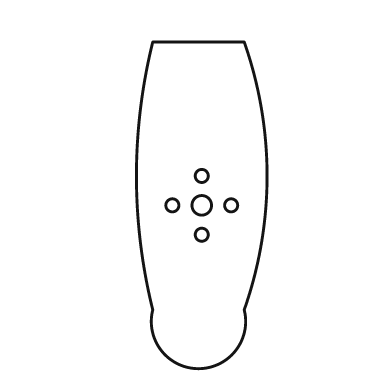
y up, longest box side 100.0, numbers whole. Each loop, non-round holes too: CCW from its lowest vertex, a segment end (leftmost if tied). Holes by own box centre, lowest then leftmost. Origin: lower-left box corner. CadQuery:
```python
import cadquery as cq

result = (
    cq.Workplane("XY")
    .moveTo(5.0, 18.0)
    .threePointArc((19.0, 0.0), (33.0, 18.0))
    .threePointArc((40.0, 59.0), (33.0, 100.0))
    .lineTo(5.0, 100.0)
    .threePointArc((0.0, 59.0), (5.0, 18.0))
    .close()
    .moveTo(20.0, 41.0)
    .circle(2.0)
    .moveTo(11.0, 50.0)
    .circle(2.0)
    .moveTo(20.0, 50.0)
    .circle(3.0)
    .moveTo(29.0, 50.0)
    .circle(2.0)
    .moveTo(20.0, 59.0)
    .circle(2.0)
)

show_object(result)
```